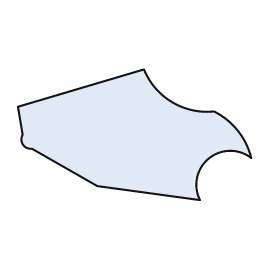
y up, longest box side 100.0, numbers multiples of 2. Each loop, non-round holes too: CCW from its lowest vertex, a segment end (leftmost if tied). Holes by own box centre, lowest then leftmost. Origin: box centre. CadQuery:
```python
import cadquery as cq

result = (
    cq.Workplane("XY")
    .moveTo(28.0, -28.0)
    .threePointArc((32.0, -10.0), (50.0, -10.0))
    .threePointArc((44.0, 2.0), (34.0, 10.0))
    .threePointArc((16.0, 14.0), (4.0, 28.0))
    .lineTo(-50.0, 12.0)
    .lineTo(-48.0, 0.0)
    .threePointArc((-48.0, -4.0), (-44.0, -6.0))
    .lineTo(-16.0, -22.0)
    .close()
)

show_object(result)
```